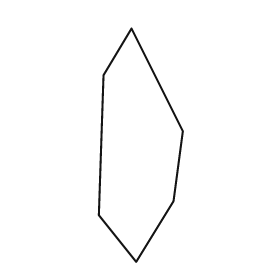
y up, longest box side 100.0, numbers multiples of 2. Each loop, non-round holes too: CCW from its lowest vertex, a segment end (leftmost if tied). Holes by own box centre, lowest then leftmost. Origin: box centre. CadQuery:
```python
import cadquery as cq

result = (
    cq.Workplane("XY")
    .moveTo(-2.0, -50.0)
    .lineTo(14.0, -24.0)
    .lineTo(18.0, 6.0)
    .lineTo(-4.0, 50.0)
    .lineTo(-16.0, 30.0)
    .lineTo(-18.0, -30.0)
    .close()
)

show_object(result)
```